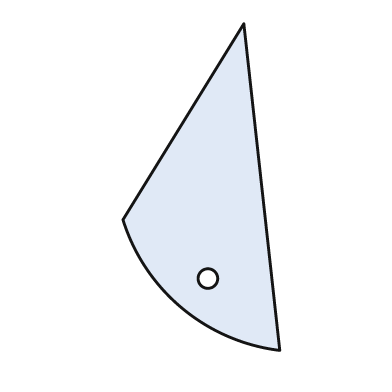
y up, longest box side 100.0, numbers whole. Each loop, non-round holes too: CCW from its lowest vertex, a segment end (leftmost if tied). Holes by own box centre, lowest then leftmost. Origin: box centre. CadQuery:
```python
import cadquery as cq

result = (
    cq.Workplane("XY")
    .moveTo(24.0, -50.0)
    .lineTo(13.0, 50.0)
    .lineTo(-24.0, -10.0)
    .threePointArc((-6.0, -37.0), (24.0, -50.0))
    .close()
    .moveTo(2.0, -28.0)
    .circle(3.0)
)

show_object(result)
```